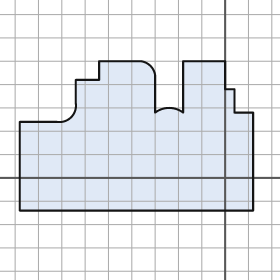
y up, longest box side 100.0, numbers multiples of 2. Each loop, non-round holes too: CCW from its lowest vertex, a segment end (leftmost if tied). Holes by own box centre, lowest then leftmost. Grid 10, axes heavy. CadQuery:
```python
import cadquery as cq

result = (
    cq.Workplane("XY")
    .moveTo(-88.0, -14.0)
    .lineTo(12.0, -14.0)
    .lineTo(12.0, 28.0)
    .lineTo(4.0, 28.0)
    .lineTo(4.0, 38.0)
    .lineTo(0.0, 38.0)
    .lineTo(0.0, 50.0)
    .lineTo(-18.0, 50.0)
    .lineTo(-18.0, 28.0)
    .threePointArc((-24.0, 30.0), (-30.0, 28.0))
    .lineTo(-30.0, 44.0)
    .threePointArc((-32.0, 48.0), (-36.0, 50.0))
    .lineTo(-54.0, 50.0)
    .lineTo(-54.0, 42.0)
    .lineTo(-64.0, 42.0)
    .lineTo(-64.0, 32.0)
    .threePointArc((-66.0, 26.0), (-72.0, 24.0))
    .lineTo(-88.0, 24.0)
    .close()
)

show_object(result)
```